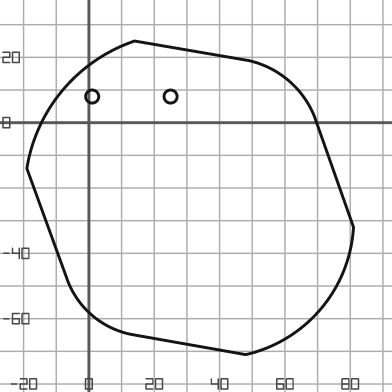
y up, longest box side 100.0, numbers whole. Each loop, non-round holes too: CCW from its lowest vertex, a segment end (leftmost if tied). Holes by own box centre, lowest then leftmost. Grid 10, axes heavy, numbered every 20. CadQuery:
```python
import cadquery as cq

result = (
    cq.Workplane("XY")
    .moveTo(48.0, -71.0)
    .threePointArc((71.0, -57.0), (81.0, -32.0))
    .lineTo(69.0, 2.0)
    .threePointArc((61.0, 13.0), (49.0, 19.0))
    .lineTo(14.0, 25.0)
    .threePointArc((-8.0, 10.0), (-19.0, -14.0))
    .lineTo(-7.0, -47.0)
    .threePointArc((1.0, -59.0), (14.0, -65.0))
    .close()
    .moveTo(1.0, 8.0)
    .circle(2.0)
    .moveTo(25.0, 8.0)
    .circle(2.0)
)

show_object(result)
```